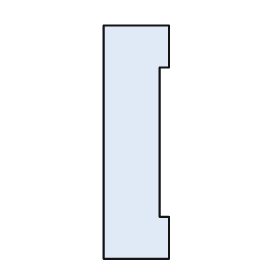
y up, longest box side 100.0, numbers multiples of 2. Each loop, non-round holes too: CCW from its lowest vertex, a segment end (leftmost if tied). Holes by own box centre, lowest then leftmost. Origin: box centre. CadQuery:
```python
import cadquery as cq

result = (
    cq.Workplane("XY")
    .moveTo(-14.0, -50.0)
    .lineTo(14.0, -50.0)
    .lineTo(14.0, -32.0)
    .lineTo(10.0, -32.0)
    .lineTo(10.0, 32.0)
    .lineTo(14.0, 32.0)
    .lineTo(14.0, 50.0)
    .lineTo(-14.0, 50.0)
    .close()
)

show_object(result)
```